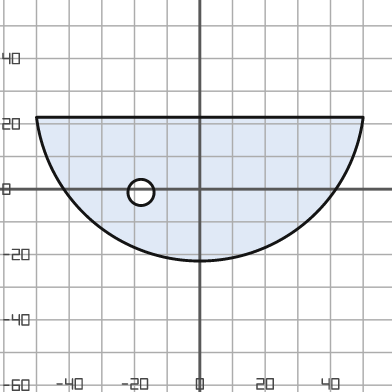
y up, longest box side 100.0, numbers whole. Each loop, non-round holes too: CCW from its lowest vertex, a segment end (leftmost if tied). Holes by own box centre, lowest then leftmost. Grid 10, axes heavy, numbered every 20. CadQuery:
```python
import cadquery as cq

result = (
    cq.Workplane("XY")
    .moveTo(-50.0, 22.0)
    .threePointArc((0.0, -22.0), (50.0, 22.0))
    .close()
    .moveTo(-18.0, -1.0)
    .circle(4.0)
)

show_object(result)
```